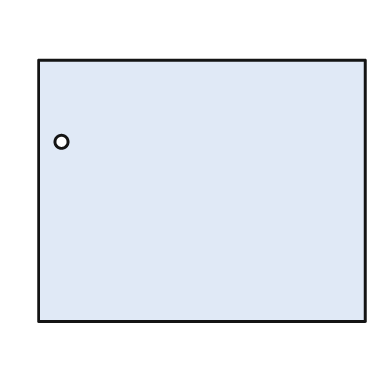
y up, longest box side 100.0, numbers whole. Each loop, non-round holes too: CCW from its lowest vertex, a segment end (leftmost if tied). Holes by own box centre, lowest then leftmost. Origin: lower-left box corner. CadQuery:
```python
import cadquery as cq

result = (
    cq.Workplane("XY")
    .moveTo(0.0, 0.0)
    .lineTo(100.0, 0.0)
    .lineTo(100.0, 80.0)
    .lineTo(0.0, 80.0)
    .close()
    .moveTo(7.0, 55.0)
    .circle(2.0)
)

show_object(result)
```